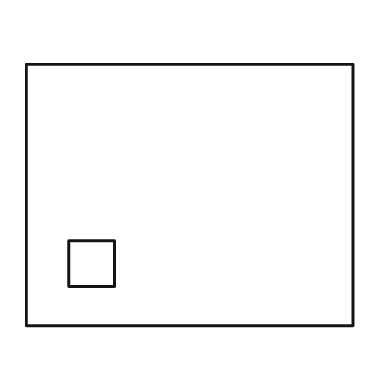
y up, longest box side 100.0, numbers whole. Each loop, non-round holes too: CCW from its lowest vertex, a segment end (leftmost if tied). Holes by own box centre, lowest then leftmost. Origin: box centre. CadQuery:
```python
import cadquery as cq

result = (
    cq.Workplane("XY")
    .moveTo(-50.0, -40.0)
    .lineTo(50.0, -40.0)
    .lineTo(50.0, 40.0)
    .lineTo(-50.0, 40.0)
    .close()
    .moveTo(-37.0, -28.0)
    .lineTo(-23.0, -28.0)
    .lineTo(-23.0, -14.0)
    .lineTo(-37.0, -14.0)
    .close()
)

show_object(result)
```